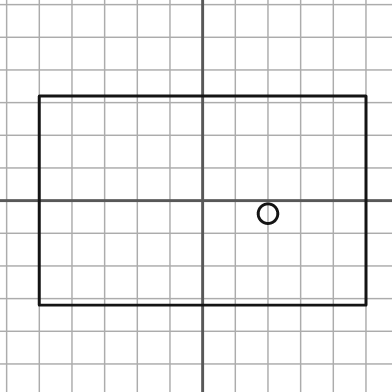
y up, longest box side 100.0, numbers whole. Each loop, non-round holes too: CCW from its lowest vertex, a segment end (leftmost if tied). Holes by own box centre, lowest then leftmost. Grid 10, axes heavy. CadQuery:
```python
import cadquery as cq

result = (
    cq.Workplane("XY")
    .moveTo(-50.0, -32.0)
    .lineTo(50.0, -32.0)
    .lineTo(50.0, 32.0)
    .lineTo(-50.0, 32.0)
    .close()
    .moveTo(20.0, -4.0)
    .circle(3.0)
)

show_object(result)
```